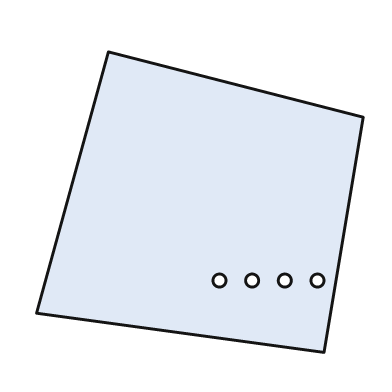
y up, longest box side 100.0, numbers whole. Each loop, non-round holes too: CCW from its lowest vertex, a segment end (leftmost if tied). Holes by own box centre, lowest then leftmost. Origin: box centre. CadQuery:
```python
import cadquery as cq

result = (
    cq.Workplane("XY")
    .moveTo(38.0, -46.0)
    .lineTo(50.0, 26.0)
    .lineTo(-28.0, 46.0)
    .lineTo(-50.0, -34.0)
    .close()
    .moveTo(6.0, -24.0)
    .circle(2.0)
    .moveTo(16.0, -24.0)
    .circle(2.0)
    .moveTo(26.0, -24.0)
    .circle(2.0)
    .moveTo(36.0, -24.0)
    .circle(2.0)
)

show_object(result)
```